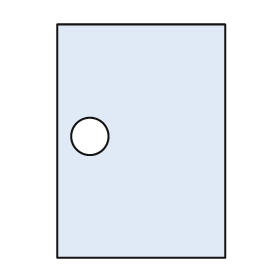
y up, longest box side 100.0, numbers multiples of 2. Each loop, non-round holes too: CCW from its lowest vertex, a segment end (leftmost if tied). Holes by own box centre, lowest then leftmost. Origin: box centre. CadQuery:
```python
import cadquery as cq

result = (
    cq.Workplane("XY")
    .moveTo(-36.0, -50.0)
    .lineTo(36.0, -50.0)
    .lineTo(36.0, 50.0)
    .lineTo(-36.0, 50.0)
    .close()
    .moveTo(-22.0, 2.0)
    .circle(8.0)
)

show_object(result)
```